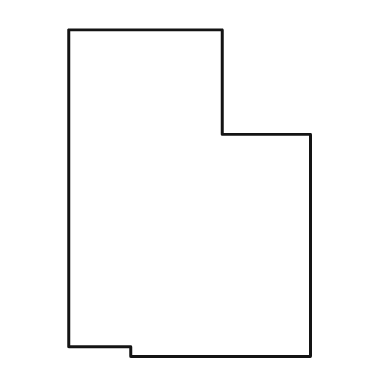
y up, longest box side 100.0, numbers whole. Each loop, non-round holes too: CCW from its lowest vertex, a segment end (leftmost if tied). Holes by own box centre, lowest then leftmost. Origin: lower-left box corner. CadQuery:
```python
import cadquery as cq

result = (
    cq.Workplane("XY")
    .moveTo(19.0, 0.0)
    .lineTo(74.0, 0.0)
    .lineTo(74.0, 68.0)
    .lineTo(47.0, 68.0)
    .lineTo(47.0, 100.0)
    .lineTo(0.0, 100.0)
    .lineTo(0.0, 3.0)
    .lineTo(19.0, 3.0)
    .close()
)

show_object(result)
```